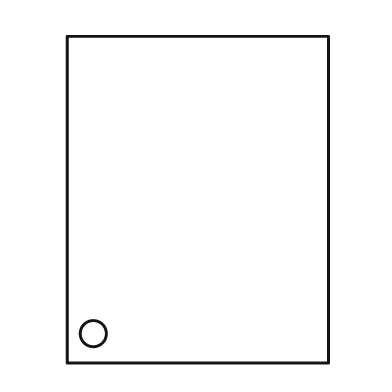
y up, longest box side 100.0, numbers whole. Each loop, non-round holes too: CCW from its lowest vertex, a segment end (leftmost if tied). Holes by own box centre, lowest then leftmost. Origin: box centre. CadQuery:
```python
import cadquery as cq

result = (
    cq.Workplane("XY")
    .moveTo(-40.0, -50.0)
    .lineTo(40.0, -50.0)
    .lineTo(40.0, 50.0)
    .lineTo(-40.0, 50.0)
    .close()
    .moveTo(-32.0, -41.0)
    .circle(4.0)
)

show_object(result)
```